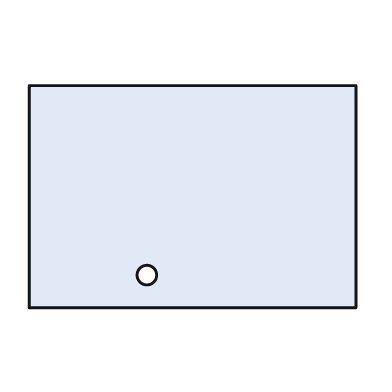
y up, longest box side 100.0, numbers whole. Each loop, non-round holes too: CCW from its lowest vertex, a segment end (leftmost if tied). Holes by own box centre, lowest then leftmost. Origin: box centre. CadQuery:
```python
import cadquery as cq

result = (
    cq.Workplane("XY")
    .moveTo(-50.0, -34.0)
    .lineTo(50.0, -34.0)
    .lineTo(50.0, 34.0)
    .lineTo(-50.0, 34.0)
    .close()
    .moveTo(-14.0, -24.0)
    .circle(3.0)
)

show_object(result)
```